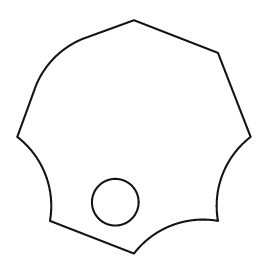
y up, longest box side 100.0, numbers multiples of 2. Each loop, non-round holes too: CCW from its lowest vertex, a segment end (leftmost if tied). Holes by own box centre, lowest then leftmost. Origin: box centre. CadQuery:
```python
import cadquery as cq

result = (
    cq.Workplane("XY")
    .moveTo(0.0, -50.0)
    .threePointArc((16.0, -38.0), (36.0, -36.0))
    .threePointArc((38.0, -16.0), (50.0, 0.0))
    .lineTo(36.0, 36.0)
    .lineTo(0.0, 50.0)
    .lineTo(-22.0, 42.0)
    .threePointArc((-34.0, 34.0), (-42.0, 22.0))
    .lineTo(-50.0, 0.0)
    .threePointArc((-38.0, -16.0), (-36.0, -36.0))
    .close()
    .moveTo(-8.0, -28.0)
    .circle(10.0)
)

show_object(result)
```